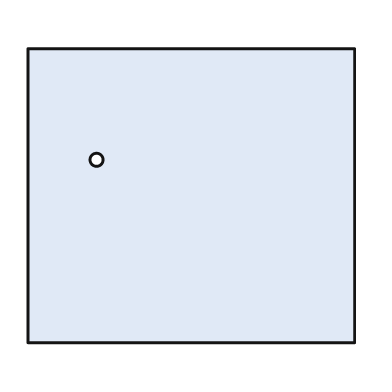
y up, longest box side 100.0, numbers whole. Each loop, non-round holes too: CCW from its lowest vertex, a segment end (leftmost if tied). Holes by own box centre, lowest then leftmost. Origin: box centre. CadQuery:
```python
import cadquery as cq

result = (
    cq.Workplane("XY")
    .moveTo(-50.0, -45.0)
    .lineTo(50.0, -45.0)
    .lineTo(50.0, 45.0)
    .lineTo(-50.0, 45.0)
    .close()
    .moveTo(-29.0, 11.0)
    .circle(2.0)
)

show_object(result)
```